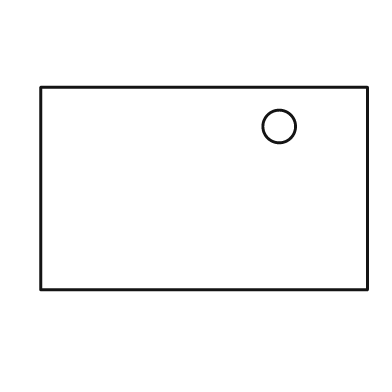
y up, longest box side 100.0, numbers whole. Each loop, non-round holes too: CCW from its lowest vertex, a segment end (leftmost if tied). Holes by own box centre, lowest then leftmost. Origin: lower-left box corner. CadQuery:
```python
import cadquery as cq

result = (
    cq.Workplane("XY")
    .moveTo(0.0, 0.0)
    .lineTo(100.0, 0.0)
    .lineTo(100.0, 62.0)
    .lineTo(0.0, 62.0)
    .close()
    .moveTo(73.0, 50.0)
    .circle(5.0)
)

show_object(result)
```